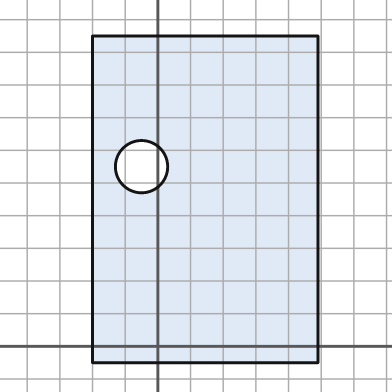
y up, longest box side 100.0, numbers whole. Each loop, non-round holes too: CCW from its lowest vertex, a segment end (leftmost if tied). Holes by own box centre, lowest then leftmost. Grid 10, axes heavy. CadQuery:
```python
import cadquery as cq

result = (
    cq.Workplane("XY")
    .moveTo(-20.0, -5.0)
    .lineTo(49.0, -5.0)
    .lineTo(49.0, 95.0)
    .lineTo(-20.0, 95.0)
    .close()
    .moveTo(-5.0, 55.0)
    .circle(8.0)
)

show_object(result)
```